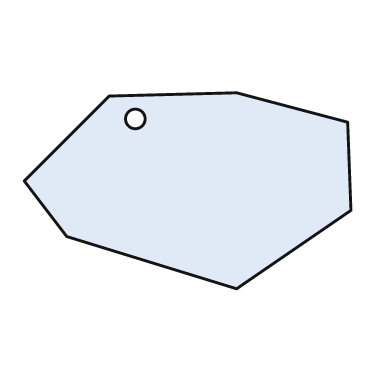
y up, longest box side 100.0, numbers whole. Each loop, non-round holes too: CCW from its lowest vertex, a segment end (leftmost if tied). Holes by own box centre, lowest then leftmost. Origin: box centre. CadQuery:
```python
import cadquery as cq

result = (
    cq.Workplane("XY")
    .moveTo(15.0, -30.0)
    .lineTo(50.0, -6.0)
    .lineTo(49.0, 21.0)
    .lineTo(15.0, 30.0)
    .lineTo(-24.0, 29.0)
    .lineTo(-50.0, 3.0)
    .lineTo(-37.0, -14.0)
    .close()
    .moveTo(-16.0, 22.0)
    .circle(3.0)
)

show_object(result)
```